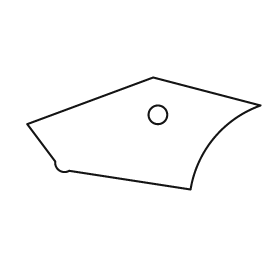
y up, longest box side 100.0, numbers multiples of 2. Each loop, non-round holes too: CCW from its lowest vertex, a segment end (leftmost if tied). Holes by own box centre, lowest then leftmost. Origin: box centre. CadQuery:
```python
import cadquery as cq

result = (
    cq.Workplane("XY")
    .moveTo(20.0, -24.0)
    .threePointArc((30.0, -2.0), (50.0, 12.0))
    .lineTo(4.0, 24.0)
    .lineTo(-50.0, 4.0)
    .lineTo(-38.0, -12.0)
    .threePointArc((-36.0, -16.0), (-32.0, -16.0))
    .close()
    .moveTo(6.0, 8.0)
    .circle(4.0)
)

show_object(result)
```